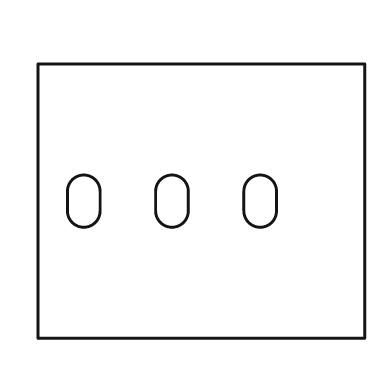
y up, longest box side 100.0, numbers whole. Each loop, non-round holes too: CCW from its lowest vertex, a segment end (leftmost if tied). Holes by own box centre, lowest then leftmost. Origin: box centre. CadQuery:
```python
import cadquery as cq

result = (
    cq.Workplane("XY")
    .moveTo(-50.0, -42.0)
    .lineTo(50.0, -42.0)
    .lineTo(50.0, 42.0)
    .lineTo(-50.0, 42.0)
    .close()
    .moveTo(-41.0, -3.0)
    .threePointArc((-36.0, -8.0), (-31.0, -3.0))
    .lineTo(-31.0, 3.0)
    .threePointArc((-36.0, 8.0), (-41.0, 3.0))
    .close()
    .moveTo(-14.0, -3.0)
    .threePointArc((-9.0, -8.0), (-4.0, -3.0))
    .lineTo(-4.0, 3.0)
    .threePointArc((-9.0, 8.0), (-14.0, 3.0))
    .close()
    .moveTo(13.0, -3.0)
    .threePointArc((18.0, -8.0), (23.0, -3.0))
    .lineTo(23.0, 3.0)
    .threePointArc((18.0, 8.0), (13.0, 3.0))
    .close()
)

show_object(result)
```